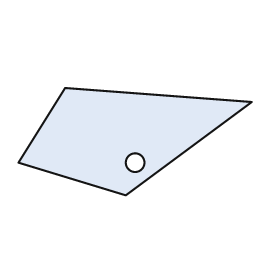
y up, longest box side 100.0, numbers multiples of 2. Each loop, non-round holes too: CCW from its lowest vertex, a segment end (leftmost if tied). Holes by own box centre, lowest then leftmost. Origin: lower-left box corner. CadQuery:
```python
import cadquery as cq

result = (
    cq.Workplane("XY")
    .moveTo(46.0, 0.0)
    .lineTo(100.0, 40.0)
    .lineTo(20.0, 46.0)
    .lineTo(0.0, 14.0)
    .close()
    .moveTo(50.0, 14.0)
    .circle(4.0)
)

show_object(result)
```